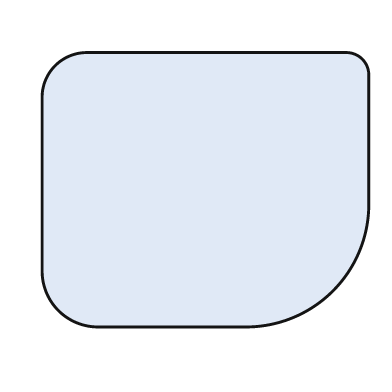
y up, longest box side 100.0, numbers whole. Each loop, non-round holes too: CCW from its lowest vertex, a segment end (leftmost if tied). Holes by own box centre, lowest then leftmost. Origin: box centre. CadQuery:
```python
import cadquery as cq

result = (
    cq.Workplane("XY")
    .moveTo(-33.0, -42.0)
    .lineTo(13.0, -42.0)
    .threePointArc((39.0, -31.0), (50.0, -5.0))
    .lineTo(50.0, 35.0)
    .threePointArc((48.0, 40.0), (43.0, 42.0))
    .lineTo(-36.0, 42.0)
    .threePointArc((-46.0, 38.0), (-50.0, 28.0))
    .lineTo(-50.0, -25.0)
    .threePointArc((-45.0, -37.0), (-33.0, -42.0))
    .close()
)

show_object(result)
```